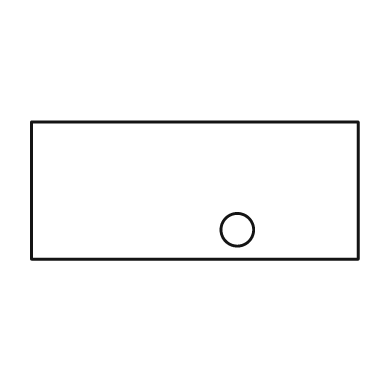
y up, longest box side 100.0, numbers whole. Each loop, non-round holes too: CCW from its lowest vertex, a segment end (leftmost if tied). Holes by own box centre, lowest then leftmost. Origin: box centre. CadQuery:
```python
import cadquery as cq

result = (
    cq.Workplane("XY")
    .moveTo(-50.0, -21.0)
    .lineTo(50.0, -21.0)
    .lineTo(50.0, 21.0)
    .lineTo(-50.0, 21.0)
    .close()
    .moveTo(13.0, -12.0)
    .circle(5.0)
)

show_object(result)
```